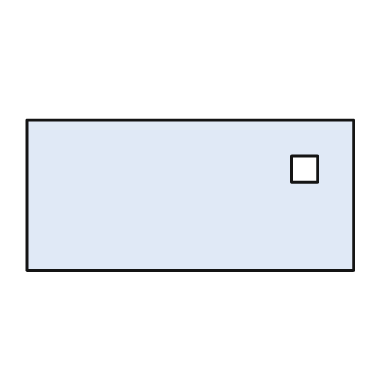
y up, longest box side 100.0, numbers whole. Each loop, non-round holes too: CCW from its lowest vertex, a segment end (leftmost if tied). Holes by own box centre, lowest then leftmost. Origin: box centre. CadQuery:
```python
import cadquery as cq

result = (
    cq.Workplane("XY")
    .moveTo(-50.0, -23.0)
    .lineTo(50.0, -23.0)
    .lineTo(50.0, 23.0)
    .lineTo(-50.0, 23.0)
    .close()
    .moveTo(31.0, 4.0)
    .lineTo(39.0, 4.0)
    .lineTo(39.0, 12.0)
    .lineTo(31.0, 12.0)
    .close()
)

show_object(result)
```